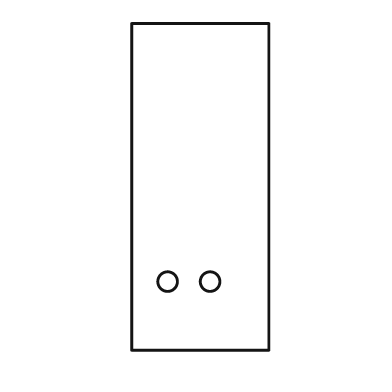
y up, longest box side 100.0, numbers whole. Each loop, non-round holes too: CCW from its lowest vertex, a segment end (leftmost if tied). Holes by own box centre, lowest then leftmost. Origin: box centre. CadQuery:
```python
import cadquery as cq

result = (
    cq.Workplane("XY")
    .moveTo(-21.0, -50.0)
    .lineTo(21.0, -50.0)
    .lineTo(21.0, 50.0)
    .lineTo(-21.0, 50.0)
    .close()
    .moveTo(-10.0, -29.0)
    .circle(3.0)
    .moveTo(3.0, -29.0)
    .circle(3.0)
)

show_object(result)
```